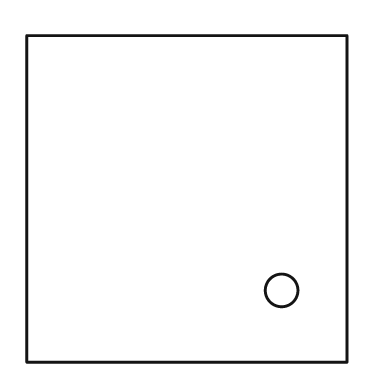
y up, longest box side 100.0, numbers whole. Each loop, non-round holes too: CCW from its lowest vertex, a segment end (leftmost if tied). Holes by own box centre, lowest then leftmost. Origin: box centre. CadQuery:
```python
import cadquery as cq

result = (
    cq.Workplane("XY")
    .moveTo(-49.0, -50.0)
    .lineTo(49.0, -50.0)
    .lineTo(49.0, 50.0)
    .lineTo(-49.0, 50.0)
    .close()
    .moveTo(29.0, -28.0)
    .circle(5.0)
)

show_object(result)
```